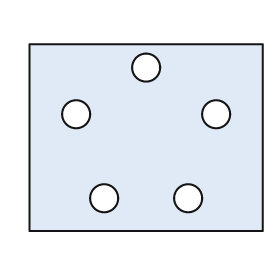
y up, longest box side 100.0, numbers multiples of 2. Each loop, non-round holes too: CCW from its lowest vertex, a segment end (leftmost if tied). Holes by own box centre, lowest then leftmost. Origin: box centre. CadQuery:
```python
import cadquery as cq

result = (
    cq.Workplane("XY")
    .moveTo(-50.0, -40.0)
    .lineTo(50.0, -40.0)
    .lineTo(50.0, 40.0)
    .lineTo(-50.0, 40.0)
    .close()
    .moveTo(-18.0, -26.0)
    .circle(6.0)
    .moveTo(18.0, -26.0)
    .circle(6.0)
    .moveTo(-30.0, 10.0)
    .circle(6.0)
    .moveTo(30.0, 10.0)
    .circle(6.0)
    .moveTo(0.0, 30.0)
    .circle(6.0)
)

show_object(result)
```